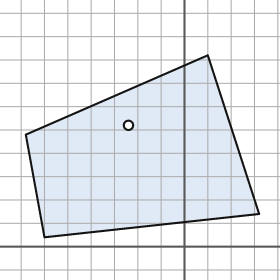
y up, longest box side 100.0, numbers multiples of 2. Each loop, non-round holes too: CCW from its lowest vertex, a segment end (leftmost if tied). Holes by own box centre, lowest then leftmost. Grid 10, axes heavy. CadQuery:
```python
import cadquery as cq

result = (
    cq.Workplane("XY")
    .moveTo(-60.0, 4.0)
    .lineTo(32.0, 14.0)
    .lineTo(10.0, 82.0)
    .lineTo(-68.0, 48.0)
    .close()
    .moveTo(-24.0, 52.0)
    .circle(2.0)
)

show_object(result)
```